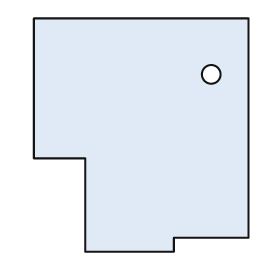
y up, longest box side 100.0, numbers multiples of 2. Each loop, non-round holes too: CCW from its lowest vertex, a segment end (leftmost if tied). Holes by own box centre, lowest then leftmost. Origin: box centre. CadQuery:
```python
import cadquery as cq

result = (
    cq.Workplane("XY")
    .moveTo(-24.0, -50.0)
    .lineTo(14.0, -50.0)
    .lineTo(14.0, -44.0)
    .lineTo(46.0, -44.0)
    .lineTo(46.0, 50.0)
    .lineTo(-46.0, 50.0)
    .lineTo(-46.0, -10.0)
    .lineTo(-24.0, -10.0)
    .close()
    .moveTo(30.0, 26.0)
    .circle(4.0)
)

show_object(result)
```